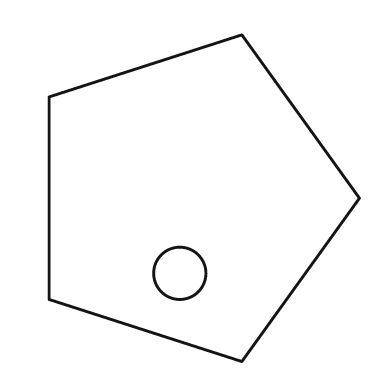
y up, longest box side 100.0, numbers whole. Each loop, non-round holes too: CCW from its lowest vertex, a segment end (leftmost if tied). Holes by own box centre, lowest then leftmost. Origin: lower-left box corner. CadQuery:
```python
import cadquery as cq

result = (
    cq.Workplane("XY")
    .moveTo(59.0, 0.0)
    .lineTo(95.0, 50.0)
    .lineTo(59.0, 100.0)
    .lineTo(0.0, 81.0)
    .lineTo(0.0, 19.0)
    .close()
    .moveTo(40.0, 27.0)
    .circle(8.0)
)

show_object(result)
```